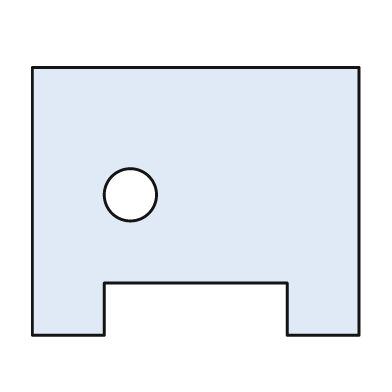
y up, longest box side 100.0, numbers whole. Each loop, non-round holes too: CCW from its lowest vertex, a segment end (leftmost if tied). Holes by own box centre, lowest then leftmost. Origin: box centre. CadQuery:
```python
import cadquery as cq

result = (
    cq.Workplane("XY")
    .moveTo(-50.0, -41.0)
    .lineTo(-28.0, -41.0)
    .lineTo(-28.0, -25.0)
    .lineTo(28.0, -25.0)
    .lineTo(28.0, -41.0)
    .lineTo(50.0, -41.0)
    .lineTo(50.0, 41.0)
    .lineTo(-50.0, 41.0)
    .close()
    .moveTo(-20.0, 2.0)
    .circle(8.0)
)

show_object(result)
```